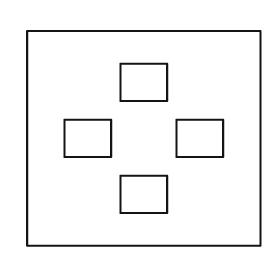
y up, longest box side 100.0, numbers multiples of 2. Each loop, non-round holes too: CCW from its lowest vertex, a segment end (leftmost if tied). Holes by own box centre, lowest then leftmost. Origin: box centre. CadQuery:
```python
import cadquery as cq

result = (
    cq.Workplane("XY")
    .moveTo(-50.0, -46.0)
    .lineTo(50.0, -46.0)
    .lineTo(50.0, 46.0)
    .lineTo(-50.0, 46.0)
    .close()
    .moveTo(-10.0, -32.0)
    .lineTo(10.0, -32.0)
    .lineTo(10.0, -16.0)
    .lineTo(-10.0, -16.0)
    .close()
    .moveTo(-34.0, -8.0)
    .lineTo(-14.0, -8.0)
    .lineTo(-14.0, 8.0)
    .lineTo(-34.0, 8.0)
    .close()
    .moveTo(14.0, -8.0)
    .lineTo(34.0, -8.0)
    .lineTo(34.0, 8.0)
    .lineTo(14.0, 8.0)
    .close()
    .moveTo(-10.0, 16.0)
    .lineTo(10.0, 16.0)
    .lineTo(10.0, 32.0)
    .lineTo(-10.0, 32.0)
    .close()
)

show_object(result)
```